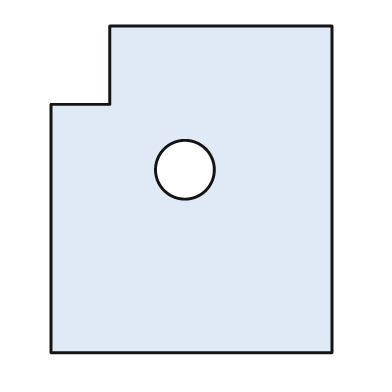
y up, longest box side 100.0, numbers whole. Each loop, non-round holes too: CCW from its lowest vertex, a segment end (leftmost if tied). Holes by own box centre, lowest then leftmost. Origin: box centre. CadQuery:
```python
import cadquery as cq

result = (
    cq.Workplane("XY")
    .moveTo(-43.0, -50.0)
    .lineTo(43.0, -50.0)
    .lineTo(43.0, 50.0)
    .lineTo(-25.0, 50.0)
    .lineTo(-25.0, 26.0)
    .lineTo(-43.0, 26.0)
    .close()
    .moveTo(-2.0, 6.0)
    .circle(9.0)
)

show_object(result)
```